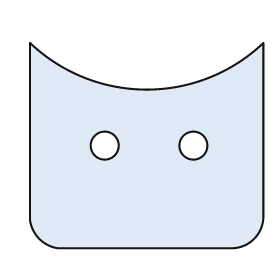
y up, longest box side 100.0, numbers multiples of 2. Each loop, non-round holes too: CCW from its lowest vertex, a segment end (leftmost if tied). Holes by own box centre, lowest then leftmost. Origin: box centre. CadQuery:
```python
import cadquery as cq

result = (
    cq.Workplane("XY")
    .moveTo(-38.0, -44.0)
    .lineTo(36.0, -44.0)
    .threePointArc((46.0, -40.0), (50.0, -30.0))
    .lineTo(50.0, 44.0)
    .threePointArc((0.0, 24.0), (-50.0, 44.0))
    .lineTo(-50.0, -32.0)
    .threePointArc((-46.0, -40.0), (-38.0, -44.0))
    .close()
    .moveTo(-18.0, 0.0)
    .circle(6.0)
    .moveTo(20.0, 0.0)
    .circle(6.0)
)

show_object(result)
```